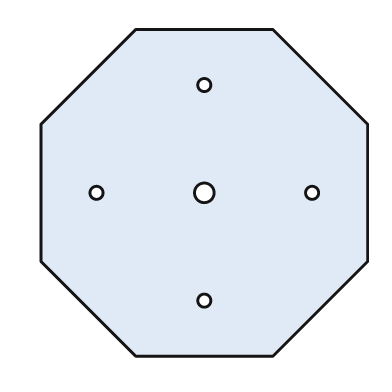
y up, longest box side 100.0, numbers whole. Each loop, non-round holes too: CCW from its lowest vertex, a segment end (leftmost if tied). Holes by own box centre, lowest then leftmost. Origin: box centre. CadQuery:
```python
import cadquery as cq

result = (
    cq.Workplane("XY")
    .moveTo(-21.0, -50.0)
    .lineTo(21.0, -50.0)
    .lineTo(50.0, -21.0)
    .lineTo(50.0, 21.0)
    .lineTo(21.0, 50.0)
    .lineTo(-21.0, 50.0)
    .lineTo(-50.0, 21.0)
    .lineTo(-50.0, -21.0)
    .close()
    .moveTo(0.0, -33.0)
    .circle(2.0)
    .moveTo(-33.0, 0.0)
    .circle(2.0)
    .moveTo(0.0, 0.0)
    .circle(3.0)
    .moveTo(33.0, 0.0)
    .circle(2.0)
    .moveTo(0.0, 33.0)
    .circle(2.0)
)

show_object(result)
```